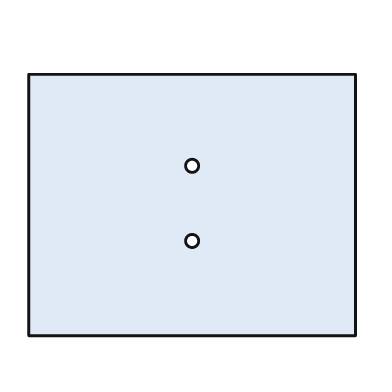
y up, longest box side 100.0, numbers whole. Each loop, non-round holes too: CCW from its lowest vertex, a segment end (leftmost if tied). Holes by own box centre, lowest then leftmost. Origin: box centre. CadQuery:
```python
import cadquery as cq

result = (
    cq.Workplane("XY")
    .moveTo(-50.0, -40.0)
    .lineTo(50.0, -40.0)
    .lineTo(50.0, 40.0)
    .lineTo(-50.0, 40.0)
    .close()
    .moveTo(0.0, -11.0)
    .circle(2.0)
    .moveTo(0.0, 12.0)
    .circle(2.0)
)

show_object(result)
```